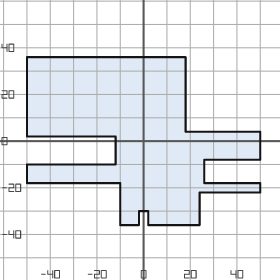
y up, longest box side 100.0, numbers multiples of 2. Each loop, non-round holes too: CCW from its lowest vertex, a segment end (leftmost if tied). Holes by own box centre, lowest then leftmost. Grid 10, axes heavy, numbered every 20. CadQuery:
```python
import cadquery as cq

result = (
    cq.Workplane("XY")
    .moveTo(-10.0, -36.0)
    .lineTo(-2.0, -36.0)
    .lineTo(-2.0, -30.0)
    .lineTo(2.0, -30.0)
    .lineTo(2.0, -36.0)
    .lineTo(24.0, -36.0)
    .lineTo(24.0, -22.0)
    .lineTo(50.0, -22.0)
    .lineTo(50.0, -18.0)
    .lineTo(26.0, -18.0)
    .lineTo(26.0, -8.0)
    .lineTo(50.0, -8.0)
    .lineTo(50.0, 4.0)
    .lineTo(18.0, 4.0)
    .lineTo(18.0, 36.0)
    .lineTo(-50.0, 36.0)
    .lineTo(-50.0, 2.0)
    .lineTo(-12.0, 2.0)
    .lineTo(-12.0, -10.0)
    .lineTo(-50.0, -10.0)
    .lineTo(-50.0, -18.0)
    .lineTo(-10.0, -18.0)
    .close()
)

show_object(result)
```